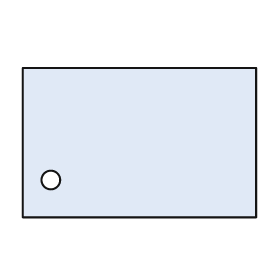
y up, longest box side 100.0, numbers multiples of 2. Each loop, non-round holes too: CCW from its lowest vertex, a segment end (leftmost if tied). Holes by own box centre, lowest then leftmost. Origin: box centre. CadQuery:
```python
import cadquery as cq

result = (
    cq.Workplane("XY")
    .moveTo(-50.0, -32.0)
    .lineTo(50.0, -32.0)
    .lineTo(50.0, 32.0)
    .lineTo(-50.0, 32.0)
    .close()
    .moveTo(-38.0, -16.0)
    .circle(4.0)
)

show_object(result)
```